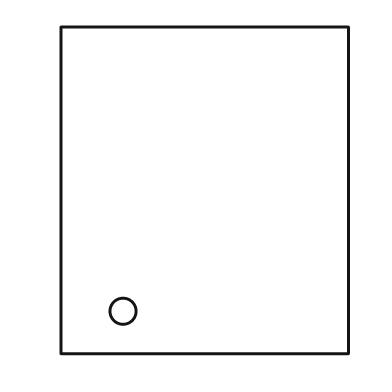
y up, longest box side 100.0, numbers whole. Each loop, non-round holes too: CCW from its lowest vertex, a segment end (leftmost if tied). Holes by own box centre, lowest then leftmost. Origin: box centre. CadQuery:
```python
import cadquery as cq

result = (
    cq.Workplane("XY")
    .moveTo(-44.0, -50.0)
    .lineTo(44.0, -50.0)
    .lineTo(44.0, 50.0)
    .lineTo(-44.0, 50.0)
    .close()
    .moveTo(-25.0, -37.0)
    .circle(4.0)
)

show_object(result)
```